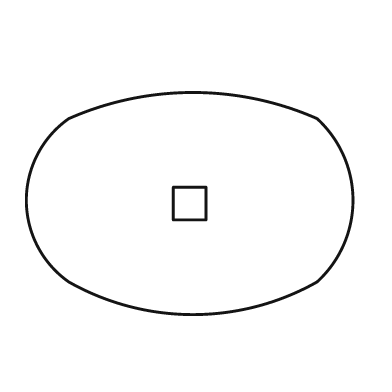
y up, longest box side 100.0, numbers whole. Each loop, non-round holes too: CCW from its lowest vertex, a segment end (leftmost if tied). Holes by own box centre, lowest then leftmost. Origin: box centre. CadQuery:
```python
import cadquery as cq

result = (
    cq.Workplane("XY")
    .moveTo(-37.0, -24.0)
    .threePointArc((1.0, -34.0), (39.0, -24.0))
    .threePointArc((50.0, 1.0), (39.0, 26.0))
    .threePointArc((1.0, 34.0), (-37.0, 26.0))
    .threePointArc((-50.0, 1.0), (-37.0, -24.0))
    .close()
    .moveTo(-5.0, -5.0)
    .lineTo(5.0, -5.0)
    .lineTo(5.0, 5.0)
    .lineTo(-5.0, 5.0)
    .close()
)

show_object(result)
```